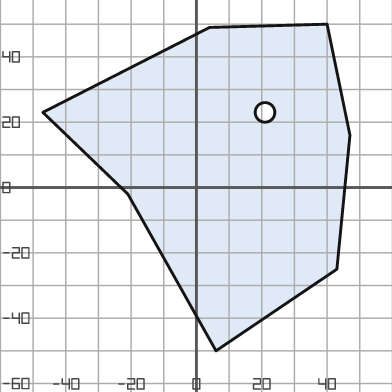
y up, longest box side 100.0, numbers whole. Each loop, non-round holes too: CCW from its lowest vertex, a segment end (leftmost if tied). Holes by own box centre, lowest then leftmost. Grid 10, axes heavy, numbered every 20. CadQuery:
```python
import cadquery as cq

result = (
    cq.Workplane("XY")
    .moveTo(6.0, -50.0)
    .lineTo(43.0, -25.0)
    .lineTo(47.0, 16.0)
    .lineTo(40.0, 50.0)
    .lineTo(4.0, 49.0)
    .lineTo(-47.0, 23.0)
    .lineTo(-21.0, -2.0)
    .close()
    .moveTo(21.0, 23.0)
    .circle(3.0)
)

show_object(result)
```